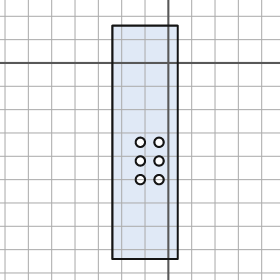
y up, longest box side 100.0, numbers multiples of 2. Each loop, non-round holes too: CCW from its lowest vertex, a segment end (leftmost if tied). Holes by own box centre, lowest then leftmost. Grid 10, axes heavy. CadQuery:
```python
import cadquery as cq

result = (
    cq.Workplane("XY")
    .moveTo(-24.0, -84.0)
    .lineTo(4.0, -84.0)
    .lineTo(4.0, 16.0)
    .lineTo(-24.0, 16.0)
    .close()
    .moveTo(-12.0, -50.0)
    .circle(2.0)
    .moveTo(-4.0, -50.0)
    .circle(2.0)
    .moveTo(-12.0, -42.0)
    .circle(2.0)
    .moveTo(-4.0, -42.0)
    .circle(2.0)
    .moveTo(-12.0, -34.0)
    .circle(2.0)
    .moveTo(-4.0, -34.0)
    .circle(2.0)
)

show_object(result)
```